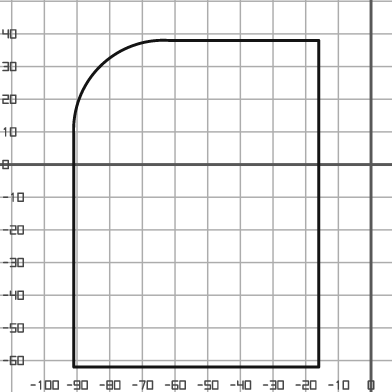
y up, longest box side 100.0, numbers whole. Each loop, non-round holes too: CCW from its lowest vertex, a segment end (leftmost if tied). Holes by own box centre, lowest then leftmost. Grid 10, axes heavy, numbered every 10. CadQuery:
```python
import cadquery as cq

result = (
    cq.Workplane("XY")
    .moveTo(-91.0, -62.0)
    .lineTo(-16.0, -62.0)
    .lineTo(-16.0, 38.0)
    .lineTo(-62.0, 38.0)
    .threePointArc((-83.0, 30.0), (-91.0, 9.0))
    .close()
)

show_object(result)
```